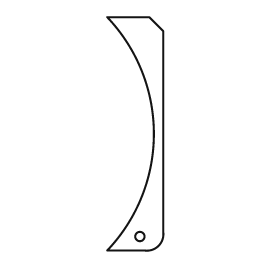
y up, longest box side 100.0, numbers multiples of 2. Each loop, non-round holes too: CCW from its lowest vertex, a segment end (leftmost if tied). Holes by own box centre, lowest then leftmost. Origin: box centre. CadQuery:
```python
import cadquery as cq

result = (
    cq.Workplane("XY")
    .moveTo(-12.0, -50.0)
    .lineTo(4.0, -50.0)
    .threePointArc((10.0, -48.0), (12.0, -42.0))
    .lineTo(12.0, 44.0)
    .lineTo(6.0, 50.0)
    .lineTo(-12.0, 50.0)
    .threePointArc((8.0, 0.0), (-12.0, -50.0))
    .close()
    .moveTo(2.0, -44.0)
    .circle(2.0)
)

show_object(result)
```